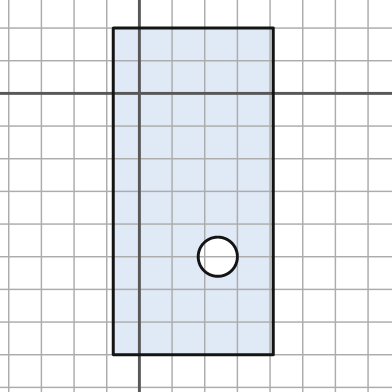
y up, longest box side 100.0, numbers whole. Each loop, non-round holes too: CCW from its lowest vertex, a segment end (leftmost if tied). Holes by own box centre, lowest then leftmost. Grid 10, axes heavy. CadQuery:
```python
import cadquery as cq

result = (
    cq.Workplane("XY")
    .moveTo(-8.0, -80.0)
    .lineTo(41.0, -80.0)
    .lineTo(41.0, 20.0)
    .lineTo(-8.0, 20.0)
    .close()
    .moveTo(24.0, -50.0)
    .circle(6.0)
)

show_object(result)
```